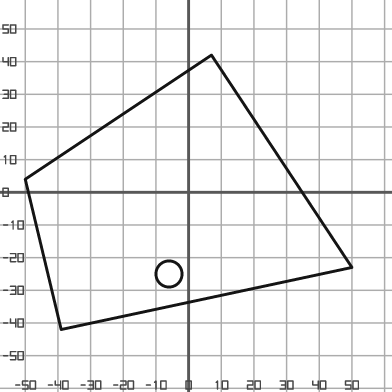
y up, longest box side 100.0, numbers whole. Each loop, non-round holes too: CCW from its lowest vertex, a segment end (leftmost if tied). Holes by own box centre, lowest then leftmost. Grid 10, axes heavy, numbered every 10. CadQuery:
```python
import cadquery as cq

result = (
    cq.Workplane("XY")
    .moveTo(-39.0, -42.0)
    .lineTo(50.0, -23.0)
    .lineTo(7.0, 42.0)
    .lineTo(-50.0, 4.0)
    .close()
    .moveTo(-6.0, -25.0)
    .circle(4.0)
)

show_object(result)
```